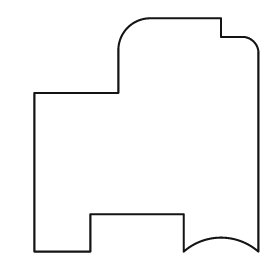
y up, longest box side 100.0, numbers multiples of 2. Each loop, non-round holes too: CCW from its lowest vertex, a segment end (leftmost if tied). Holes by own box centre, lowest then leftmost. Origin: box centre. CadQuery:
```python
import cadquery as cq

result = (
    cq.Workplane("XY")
    .moveTo(-48.0, -50.0)
    .lineTo(-24.0, -50.0)
    .lineTo(-24.0, -34.0)
    .lineTo(16.0, -34.0)
    .lineTo(16.0, -50.0)
    .threePointArc((32.0, -44.0), (48.0, -50.0))
    .lineTo(48.0, 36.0)
    .threePointArc((46.0, 40.0), (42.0, 42.0))
    .lineTo(32.0, 42.0)
    .lineTo(32.0, 50.0)
    .lineTo(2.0, 50.0)
    .threePointArc((-8.0, 46.0), (-12.0, 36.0))
    .lineTo(-12.0, 18.0)
    .lineTo(-48.0, 18.0)
    .close()
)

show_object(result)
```